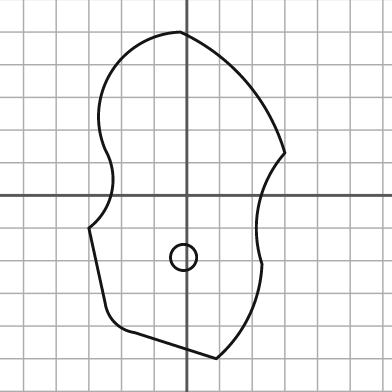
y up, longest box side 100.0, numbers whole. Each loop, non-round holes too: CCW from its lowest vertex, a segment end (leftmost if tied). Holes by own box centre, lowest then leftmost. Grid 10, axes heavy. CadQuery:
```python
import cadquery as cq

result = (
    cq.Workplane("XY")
    .moveTo(9.0, -50.0)
    .threePointArc((19.0, -37.0), (23.0, -21.0))
    .threePointArc((22.0, -3.0), (30.0, 13.0))
    .threePointArc((18.0, 35.0), (-2.0, 50.0))
    .threePointArc((-23.0, 38.0), (-25.0, 14.0))
    .threePointArc((-23.0, 1.0), (-30.0, -10.0))
    .lineTo(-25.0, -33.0)
    .threePointArc((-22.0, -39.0), (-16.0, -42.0))
    .close()
    .moveTo(-1.0, -19.0)
    .circle(4.0)
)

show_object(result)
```